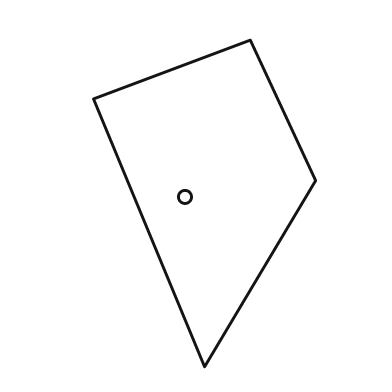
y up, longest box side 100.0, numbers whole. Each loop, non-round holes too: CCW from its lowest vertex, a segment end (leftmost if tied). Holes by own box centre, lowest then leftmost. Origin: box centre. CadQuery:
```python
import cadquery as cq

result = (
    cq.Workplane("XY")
    .moveTo(0.0, -50.0)
    .lineTo(34.0, 7.0)
    .lineTo(14.0, 50.0)
    .lineTo(-34.0, 32.0)
    .close()
    .moveTo(-6.0, 2.0)
    .circle(2.0)
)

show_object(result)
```